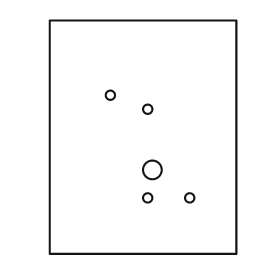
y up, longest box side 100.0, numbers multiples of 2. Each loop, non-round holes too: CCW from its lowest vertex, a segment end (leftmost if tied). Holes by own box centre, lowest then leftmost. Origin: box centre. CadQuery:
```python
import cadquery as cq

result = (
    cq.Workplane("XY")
    .moveTo(-40.0, -50.0)
    .lineTo(40.0, -50.0)
    .lineTo(40.0, 50.0)
    .lineTo(-40.0, 50.0)
    .close()
    .moveTo(2.0, -26.0)
    .circle(2.0)
    .moveTo(20.0, -26.0)
    .circle(2.0)
    .moveTo(4.0, -14.0)
    .circle(4.0)
    .moveTo(2.0, 12.0)
    .circle(2.0)
    .moveTo(-14.0, 18.0)
    .circle(2.0)
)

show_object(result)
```